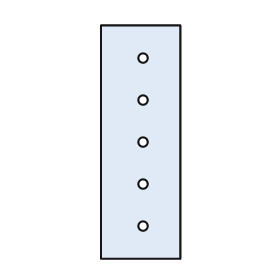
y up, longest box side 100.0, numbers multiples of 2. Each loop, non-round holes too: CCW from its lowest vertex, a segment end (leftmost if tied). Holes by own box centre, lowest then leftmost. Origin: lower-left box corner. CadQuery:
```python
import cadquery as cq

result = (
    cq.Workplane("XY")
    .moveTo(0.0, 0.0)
    .lineTo(34.0, 0.0)
    .lineTo(34.0, 100.0)
    .lineTo(0.0, 100.0)
    .close()
    .moveTo(18.0, 14.0)
    .circle(2.0)
    .moveTo(18.0, 32.0)
    .circle(2.0)
    .moveTo(18.0, 50.0)
    .circle(2.0)
    .moveTo(18.0, 68.0)
    .circle(2.0)
    .moveTo(18.0, 86.0)
    .circle(2.0)
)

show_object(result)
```